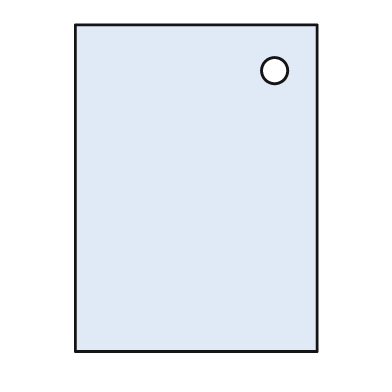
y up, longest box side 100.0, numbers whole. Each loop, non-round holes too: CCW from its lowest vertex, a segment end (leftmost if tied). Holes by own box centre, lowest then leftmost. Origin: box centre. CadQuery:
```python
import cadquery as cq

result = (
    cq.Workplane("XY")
    .moveTo(-37.0, -50.0)
    .lineTo(37.0, -50.0)
    .lineTo(37.0, 50.0)
    .lineTo(-37.0, 50.0)
    .close()
    .moveTo(24.0, 36.0)
    .circle(4.0)
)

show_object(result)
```